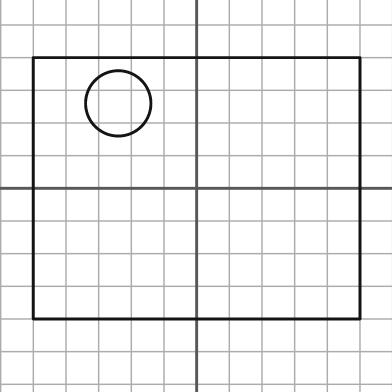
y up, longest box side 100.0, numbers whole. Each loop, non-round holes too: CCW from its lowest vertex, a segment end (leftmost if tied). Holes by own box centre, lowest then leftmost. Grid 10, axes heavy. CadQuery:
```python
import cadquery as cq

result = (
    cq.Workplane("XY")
    .moveTo(-50.0, -40.0)
    .lineTo(50.0, -40.0)
    .lineTo(50.0, 40.0)
    .lineTo(-50.0, 40.0)
    .close()
    .moveTo(-24.0, 26.0)
    .circle(10.0)
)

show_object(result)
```